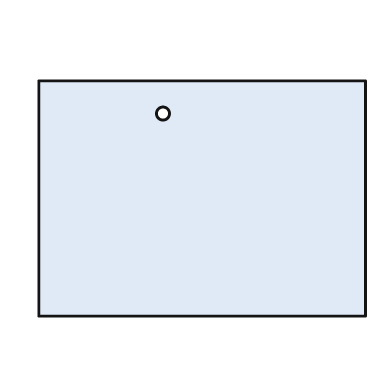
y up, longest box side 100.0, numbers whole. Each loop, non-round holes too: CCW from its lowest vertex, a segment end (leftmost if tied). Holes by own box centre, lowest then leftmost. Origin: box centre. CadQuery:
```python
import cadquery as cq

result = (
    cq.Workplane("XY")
    .moveTo(-50.0, -36.0)
    .lineTo(50.0, -36.0)
    .lineTo(50.0, 36.0)
    .lineTo(-50.0, 36.0)
    .close()
    .moveTo(-12.0, 26.0)
    .circle(2.0)
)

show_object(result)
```